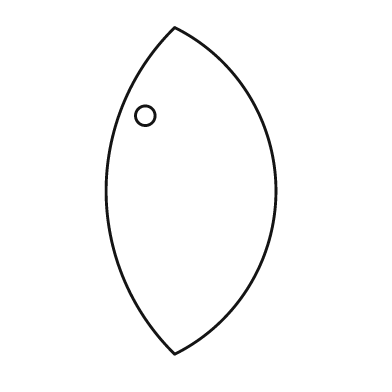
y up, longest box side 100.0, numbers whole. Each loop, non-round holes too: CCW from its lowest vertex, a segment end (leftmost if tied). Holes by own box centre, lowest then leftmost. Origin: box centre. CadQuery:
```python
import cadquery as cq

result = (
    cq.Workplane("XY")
    .moveTo(-5.0, -50.0)
    .threePointArc((26.0, 0.0), (-5.0, 50.0))
    .threePointArc((-26.0, 0.0), (-5.0, -50.0))
    .close()
    .moveTo(-14.0, 23.0)
    .circle(3.0)
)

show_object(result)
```